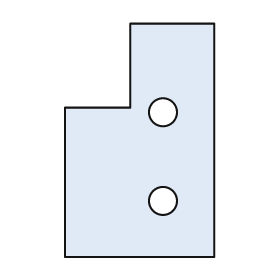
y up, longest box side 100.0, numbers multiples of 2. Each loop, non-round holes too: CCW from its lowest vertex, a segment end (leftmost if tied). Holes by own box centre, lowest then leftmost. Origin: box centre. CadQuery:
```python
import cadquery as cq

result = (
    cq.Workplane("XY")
    .moveTo(-32.0, -50.0)
    .lineTo(32.0, -50.0)
    .lineTo(32.0, 50.0)
    .lineTo(-4.0, 50.0)
    .lineTo(-4.0, 14.0)
    .lineTo(-32.0, 14.0)
    .close()
    .moveTo(10.0, -26.0)
    .circle(6.0)
    .moveTo(10.0, 12.0)
    .circle(6.0)
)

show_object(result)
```